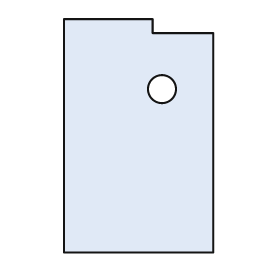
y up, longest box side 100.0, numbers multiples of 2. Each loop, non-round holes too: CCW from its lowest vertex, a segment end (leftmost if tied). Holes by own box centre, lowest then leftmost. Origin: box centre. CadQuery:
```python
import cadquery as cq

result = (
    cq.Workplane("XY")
    .moveTo(-32.0, -50.0)
    .lineTo(32.0, -50.0)
    .lineTo(32.0, 44.0)
    .lineTo(6.0, 44.0)
    .lineTo(6.0, 50.0)
    .lineTo(-32.0, 50.0)
    .close()
    .moveTo(10.0, 20.0)
    .circle(6.0)
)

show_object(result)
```